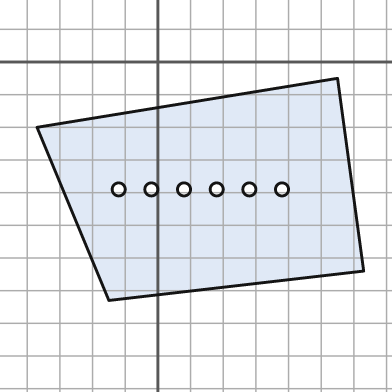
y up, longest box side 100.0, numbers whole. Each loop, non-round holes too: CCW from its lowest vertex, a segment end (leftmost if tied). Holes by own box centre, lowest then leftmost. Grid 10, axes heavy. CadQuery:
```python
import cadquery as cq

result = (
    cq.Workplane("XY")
    .moveTo(-15.0, -73.0)
    .lineTo(63.0, -64.0)
    .lineTo(55.0, -5.0)
    .lineTo(-37.0, -20.0)
    .close()
    .moveTo(-12.0, -39.0)
    .circle(2.0)
    .moveTo(-2.0, -39.0)
    .circle(2.0)
    .moveTo(8.0, -39.0)
    .circle(2.0)
    .moveTo(18.0, -39.0)
    .circle(2.0)
    .moveTo(28.0, -39.0)
    .circle(2.0)
    .moveTo(38.0, -39.0)
    .circle(2.0)
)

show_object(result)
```